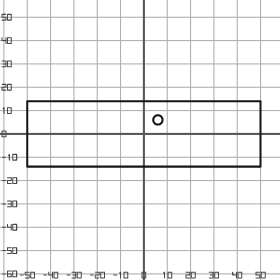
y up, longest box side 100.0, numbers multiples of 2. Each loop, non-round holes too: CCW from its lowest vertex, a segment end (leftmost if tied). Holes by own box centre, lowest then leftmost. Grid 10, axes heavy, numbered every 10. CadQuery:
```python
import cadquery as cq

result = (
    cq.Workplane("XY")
    .moveTo(-50.0, -14.0)
    .lineTo(50.0, -14.0)
    .lineTo(50.0, 14.0)
    .lineTo(-50.0, 14.0)
    .close()
    .moveTo(6.0, 6.0)
    .circle(2.0)
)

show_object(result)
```